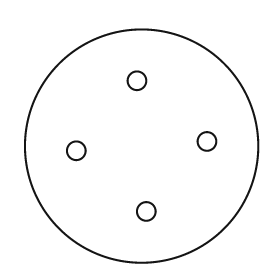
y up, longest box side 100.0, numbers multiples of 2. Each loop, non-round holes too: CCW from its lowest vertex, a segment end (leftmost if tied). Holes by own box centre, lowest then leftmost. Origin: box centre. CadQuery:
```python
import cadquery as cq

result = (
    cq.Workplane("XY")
    .moveTo(0.0, 0.0)
    .circle(50.0)
    .moveTo(2.0, -28.0)
    .circle(4.0)
    .moveTo(-28.0, -2.0)
    .circle(4.0)
    .moveTo(28.0, 2.0)
    .circle(4.0)
    .moveTo(-2.0, 28.0)
    .circle(4.0)
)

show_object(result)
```